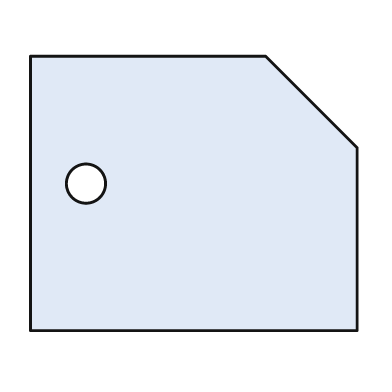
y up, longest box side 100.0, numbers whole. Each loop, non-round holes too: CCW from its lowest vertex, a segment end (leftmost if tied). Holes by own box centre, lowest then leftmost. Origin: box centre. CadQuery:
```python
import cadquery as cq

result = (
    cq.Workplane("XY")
    .moveTo(-50.0, -42.0)
    .lineTo(50.0, -42.0)
    .lineTo(50.0, 14.0)
    .lineTo(22.0, 42.0)
    .lineTo(-50.0, 42.0)
    .close()
    .moveTo(-33.0, 3.0)
    .circle(6.0)
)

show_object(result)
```